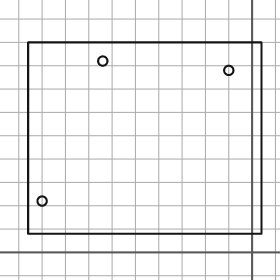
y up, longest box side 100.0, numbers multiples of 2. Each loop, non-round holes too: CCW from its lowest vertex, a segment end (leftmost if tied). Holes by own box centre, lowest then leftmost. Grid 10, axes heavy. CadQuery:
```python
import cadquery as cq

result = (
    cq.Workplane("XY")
    .moveTo(-96.0, 8.0)
    .lineTo(4.0, 8.0)
    .lineTo(4.0, 90.0)
    .lineTo(-96.0, 90.0)
    .close()
    .moveTo(-90.0, 22.0)
    .circle(2.0)
    .moveTo(-10.0, 78.0)
    .circle(2.0)
    .moveTo(-64.0, 82.0)
    .circle(2.0)
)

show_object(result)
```